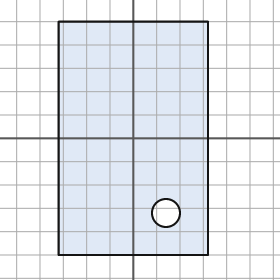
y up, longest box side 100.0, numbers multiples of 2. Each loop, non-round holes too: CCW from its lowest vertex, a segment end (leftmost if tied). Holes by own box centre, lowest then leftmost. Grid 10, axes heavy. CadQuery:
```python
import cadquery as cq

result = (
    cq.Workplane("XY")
    .moveTo(-32.0, -50.0)
    .lineTo(32.0, -50.0)
    .lineTo(32.0, 50.0)
    .lineTo(-32.0, 50.0)
    .close()
    .moveTo(14.0, -32.0)
    .circle(6.0)
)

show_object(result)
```